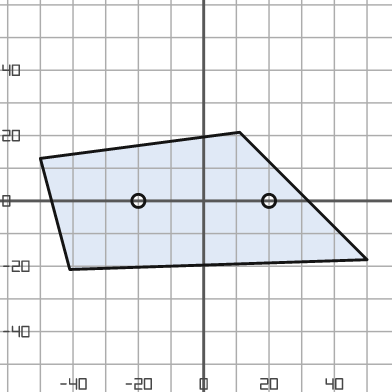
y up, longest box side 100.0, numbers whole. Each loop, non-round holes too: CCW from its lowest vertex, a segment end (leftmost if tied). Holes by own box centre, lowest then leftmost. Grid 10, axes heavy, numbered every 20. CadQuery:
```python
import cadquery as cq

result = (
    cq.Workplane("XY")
    .moveTo(-41.0, -21.0)
    .lineTo(50.0, -18.0)
    .lineTo(11.0, 21.0)
    .lineTo(-50.0, 13.0)
    .close()
    .moveTo(-20.0, 0.0)
    .circle(2.0)
    .moveTo(20.0, 0.0)
    .circle(2.0)
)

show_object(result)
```